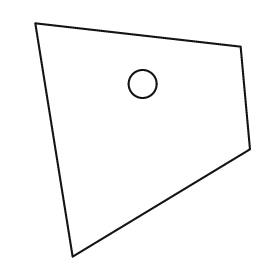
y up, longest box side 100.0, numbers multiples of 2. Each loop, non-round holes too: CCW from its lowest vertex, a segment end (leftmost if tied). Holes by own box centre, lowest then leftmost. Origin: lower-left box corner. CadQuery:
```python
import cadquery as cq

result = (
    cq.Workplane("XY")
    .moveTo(16.0, 0.0)
    .lineTo(92.0, 46.0)
    .lineTo(88.0, 90.0)
    .lineTo(0.0, 100.0)
    .close()
    .moveTo(46.0, 74.0)
    .circle(6.0)
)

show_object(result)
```